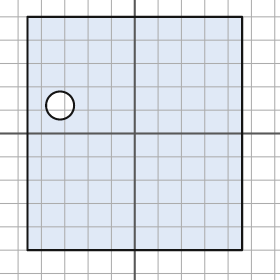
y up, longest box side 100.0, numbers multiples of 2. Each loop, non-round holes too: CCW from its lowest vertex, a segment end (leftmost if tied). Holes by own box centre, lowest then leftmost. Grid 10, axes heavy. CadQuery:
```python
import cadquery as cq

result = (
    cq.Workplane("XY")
    .moveTo(-46.0, -50.0)
    .lineTo(46.0, -50.0)
    .lineTo(46.0, 50.0)
    .lineTo(-46.0, 50.0)
    .close()
    .moveTo(-32.0, 12.0)
    .circle(6.0)
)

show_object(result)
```